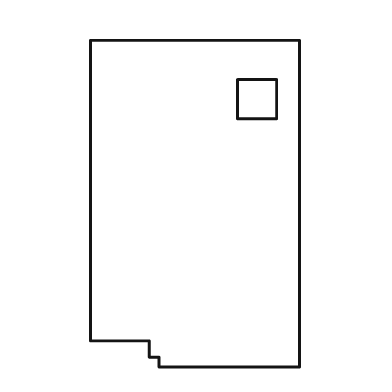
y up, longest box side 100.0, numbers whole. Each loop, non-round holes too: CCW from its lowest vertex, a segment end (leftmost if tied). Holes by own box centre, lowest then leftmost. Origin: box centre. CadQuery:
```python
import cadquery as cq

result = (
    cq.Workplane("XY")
    .moveTo(-11.0, -50.0)
    .lineTo(32.0, -50.0)
    .lineTo(32.0, 50.0)
    .lineTo(-32.0, 50.0)
    .lineTo(-32.0, -42.0)
    .lineTo(-14.0, -42.0)
    .lineTo(-14.0, -47.0)
    .lineTo(-11.0, -47.0)
    .close()
    .moveTo(13.0, 26.0)
    .lineTo(25.0, 26.0)
    .lineTo(25.0, 38.0)
    .lineTo(13.0, 38.0)
    .close()
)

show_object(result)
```